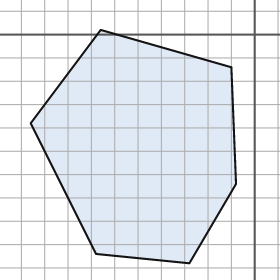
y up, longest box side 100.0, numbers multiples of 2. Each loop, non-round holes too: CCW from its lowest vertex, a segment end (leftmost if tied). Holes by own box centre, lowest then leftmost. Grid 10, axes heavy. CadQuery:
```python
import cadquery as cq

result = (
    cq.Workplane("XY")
    .moveTo(-28.0, -98.0)
    .lineTo(-8.0, -64.0)
    .lineTo(-10.0, -14.0)
    .lineTo(-66.0, 2.0)
    .lineTo(-96.0, -38.0)
    .lineTo(-68.0, -94.0)
    .close()
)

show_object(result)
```